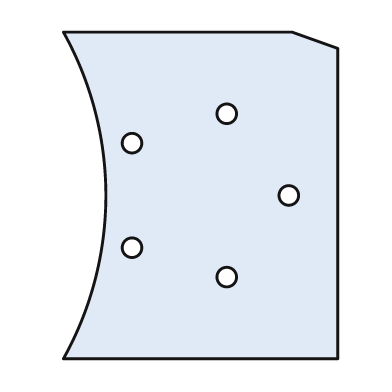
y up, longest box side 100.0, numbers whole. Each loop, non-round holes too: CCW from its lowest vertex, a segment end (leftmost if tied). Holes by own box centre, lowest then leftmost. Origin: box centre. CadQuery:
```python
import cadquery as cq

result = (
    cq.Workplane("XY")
    .moveTo(-42.0, -50.0)
    .lineTo(42.0, -50.0)
    .lineTo(42.0, 45.0)
    .lineTo(28.0, 50.0)
    .lineTo(-42.0, 50.0)
    .threePointArc((-29.0, 0.0), (-42.0, -50.0))
    .close()
    .moveTo(8.0, -25.0)
    .circle(3.0)
    .moveTo(-21.0, -16.0)
    .circle(3.0)
    .moveTo(27.0, 0.0)
    .circle(3.0)
    .moveTo(-21.0, 16.0)
    .circle(3.0)
    .moveTo(8.0, 25.0)
    .circle(3.0)
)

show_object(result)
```